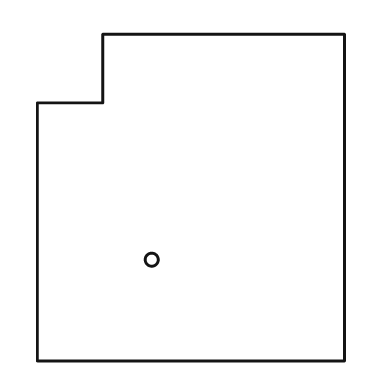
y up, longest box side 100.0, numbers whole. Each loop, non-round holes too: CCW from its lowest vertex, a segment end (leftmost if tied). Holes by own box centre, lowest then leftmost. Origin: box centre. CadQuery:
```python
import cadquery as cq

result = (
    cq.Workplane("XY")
    .moveTo(-47.0, -50.0)
    .lineTo(47.0, -50.0)
    .lineTo(47.0, 50.0)
    .lineTo(-27.0, 50.0)
    .lineTo(-27.0, 29.0)
    .lineTo(-47.0, 29.0)
    .close()
    .moveTo(-12.0, -19.0)
    .circle(2.0)
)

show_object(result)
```